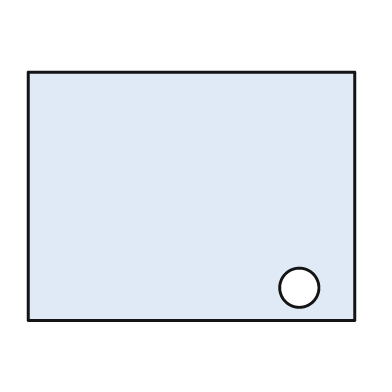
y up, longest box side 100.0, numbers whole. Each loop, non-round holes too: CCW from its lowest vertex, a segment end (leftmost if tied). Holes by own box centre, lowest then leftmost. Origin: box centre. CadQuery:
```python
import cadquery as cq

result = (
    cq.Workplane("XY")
    .moveTo(-50.0, -38.0)
    .lineTo(50.0, -38.0)
    .lineTo(50.0, 38.0)
    .lineTo(-50.0, 38.0)
    .close()
    .moveTo(33.0, -28.0)
    .circle(6.0)
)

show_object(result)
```